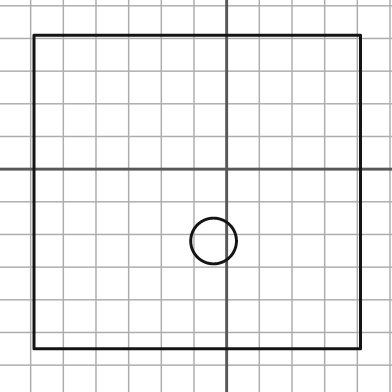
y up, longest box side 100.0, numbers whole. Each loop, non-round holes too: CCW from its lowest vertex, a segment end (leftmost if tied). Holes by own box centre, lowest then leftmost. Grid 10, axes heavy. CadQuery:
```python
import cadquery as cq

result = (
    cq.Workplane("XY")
    .moveTo(-59.0, -55.0)
    .lineTo(41.0, -55.0)
    .lineTo(41.0, 41.0)
    .lineTo(-59.0, 41.0)
    .close()
    .moveTo(-4.0, -22.0)
    .circle(7.0)
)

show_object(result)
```